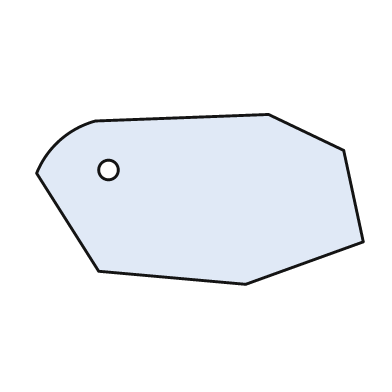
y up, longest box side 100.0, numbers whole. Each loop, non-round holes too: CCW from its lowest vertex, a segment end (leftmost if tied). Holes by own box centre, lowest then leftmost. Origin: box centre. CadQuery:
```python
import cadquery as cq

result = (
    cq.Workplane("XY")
    .moveTo(14.0, -26.0)
    .lineTo(50.0, -13.0)
    .lineTo(44.0, 15.0)
    .lineTo(21.0, 26.0)
    .lineTo(-32.0, 24.0)
    .threePointArc((-43.0, 18.0), (-50.0, 8.0))
    .lineTo(-31.0, -22.0)
    .close()
    .moveTo(-28.0, 9.0)
    .circle(3.0)
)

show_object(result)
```